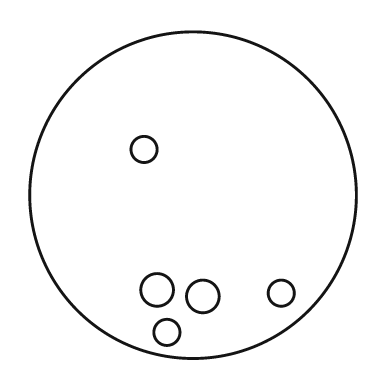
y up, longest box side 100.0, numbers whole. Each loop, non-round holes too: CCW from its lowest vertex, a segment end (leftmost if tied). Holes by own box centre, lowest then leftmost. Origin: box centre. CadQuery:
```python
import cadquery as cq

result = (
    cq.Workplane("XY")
    .moveTo(0.0, 0.0)
    .circle(50.0)
    .moveTo(-8.0, -42.0)
    .circle(4.0)
    .moveTo(3.0, -31.0)
    .circle(5.0)
    .moveTo(27.0, -30.0)
    .circle(4.0)
    .moveTo(-11.0, -29.0)
    .circle(5.0)
    .moveTo(-15.0, 14.0)
    .circle(4.0)
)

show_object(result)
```